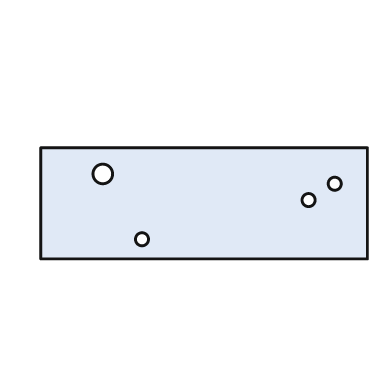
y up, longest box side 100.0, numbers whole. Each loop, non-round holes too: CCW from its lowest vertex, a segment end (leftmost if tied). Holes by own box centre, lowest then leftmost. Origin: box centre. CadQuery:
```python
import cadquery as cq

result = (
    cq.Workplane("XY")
    .moveTo(-50.0, -17.0)
    .lineTo(50.0, -17.0)
    .lineTo(50.0, 17.0)
    .lineTo(-50.0, 17.0)
    .close()
    .moveTo(-19.0, -11.0)
    .circle(2.0)
    .moveTo(32.0, 1.0)
    .circle(2.0)
    .moveTo(40.0, 6.0)
    .circle(2.0)
    .moveTo(-31.0, 9.0)
    .circle(3.0)
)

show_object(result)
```